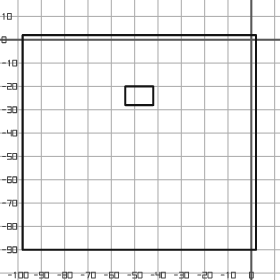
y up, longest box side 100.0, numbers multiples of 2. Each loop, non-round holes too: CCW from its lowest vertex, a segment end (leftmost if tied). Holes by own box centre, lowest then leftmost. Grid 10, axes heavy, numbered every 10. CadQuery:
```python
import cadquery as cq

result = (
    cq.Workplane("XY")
    .moveTo(-98.0, -90.0)
    .lineTo(2.0, -90.0)
    .lineTo(2.0, 2.0)
    .lineTo(-98.0, 2.0)
    .close()
    .moveTo(-54.0, -28.0)
    .lineTo(-42.0, -28.0)
    .lineTo(-42.0, -20.0)
    .lineTo(-54.0, -20.0)
    .close()
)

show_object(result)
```